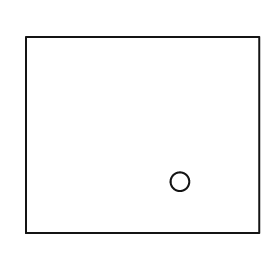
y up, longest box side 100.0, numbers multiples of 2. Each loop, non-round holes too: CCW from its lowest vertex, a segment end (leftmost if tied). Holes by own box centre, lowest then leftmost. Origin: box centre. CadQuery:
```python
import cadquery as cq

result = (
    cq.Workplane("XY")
    .moveTo(-50.0, -42.0)
    .lineTo(50.0, -42.0)
    .lineTo(50.0, 42.0)
    .lineTo(-50.0, 42.0)
    .close()
    .moveTo(16.0, -20.0)
    .circle(4.0)
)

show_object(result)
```